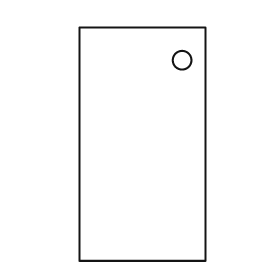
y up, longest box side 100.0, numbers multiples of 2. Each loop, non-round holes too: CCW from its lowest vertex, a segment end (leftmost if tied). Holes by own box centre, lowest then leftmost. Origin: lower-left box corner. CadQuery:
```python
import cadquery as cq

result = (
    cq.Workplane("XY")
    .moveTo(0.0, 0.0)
    .lineTo(54.0, 0.0)
    .lineTo(54.0, 100.0)
    .lineTo(0.0, 100.0)
    .close()
    .moveTo(44.0, 86.0)
    .circle(4.0)
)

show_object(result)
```